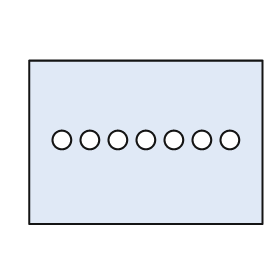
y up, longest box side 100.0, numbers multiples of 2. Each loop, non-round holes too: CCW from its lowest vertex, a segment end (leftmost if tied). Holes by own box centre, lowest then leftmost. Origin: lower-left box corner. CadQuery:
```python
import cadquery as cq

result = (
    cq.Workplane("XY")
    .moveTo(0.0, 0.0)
    .lineTo(100.0, 0.0)
    .lineTo(100.0, 70.0)
    .lineTo(0.0, 70.0)
    .close()
    .moveTo(14.0, 36.0)
    .circle(4.0)
    .moveTo(26.0, 36.0)
    .circle(4.0)
    .moveTo(38.0, 36.0)
    .circle(4.0)
    .moveTo(50.0, 36.0)
    .circle(4.0)
    .moveTo(62.0, 36.0)
    .circle(4.0)
    .moveTo(74.0, 36.0)
    .circle(4.0)
    .moveTo(86.0, 36.0)
    .circle(4.0)
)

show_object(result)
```